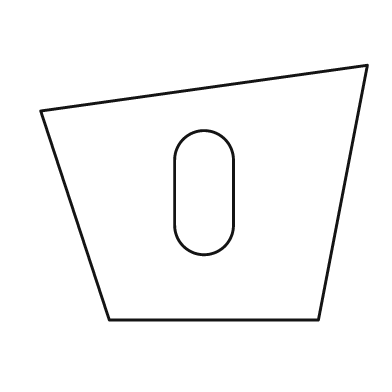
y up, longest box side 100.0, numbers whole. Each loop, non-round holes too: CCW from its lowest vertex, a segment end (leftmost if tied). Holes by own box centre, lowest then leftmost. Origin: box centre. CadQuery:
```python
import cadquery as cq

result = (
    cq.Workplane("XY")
    .moveTo(-29.0, -39.0)
    .lineTo(35.0, -39.0)
    .lineTo(50.0, 39.0)
    .lineTo(-50.0, 25.0)
    .close()
    .moveTo(-9.0, -10.0)
    .threePointArc((0.0, -19.0), (9.0, -10.0))
    .lineTo(9.0, 10.0)
    .threePointArc((0.0, 19.0), (-9.0, 10.0))
    .close()
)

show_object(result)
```